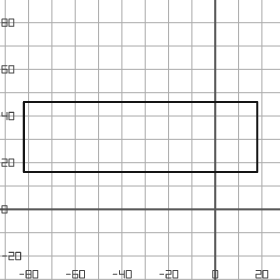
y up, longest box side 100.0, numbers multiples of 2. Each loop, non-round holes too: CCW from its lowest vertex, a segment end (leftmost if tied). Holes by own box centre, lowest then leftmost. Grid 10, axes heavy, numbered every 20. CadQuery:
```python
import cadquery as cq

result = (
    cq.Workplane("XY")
    .moveTo(-82.0, 16.0)
    .lineTo(18.0, 16.0)
    .lineTo(18.0, 46.0)
    .lineTo(-82.0, 46.0)
    .close()
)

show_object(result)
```